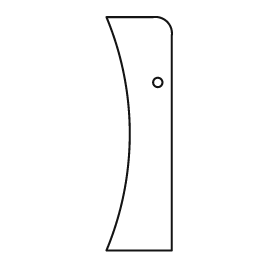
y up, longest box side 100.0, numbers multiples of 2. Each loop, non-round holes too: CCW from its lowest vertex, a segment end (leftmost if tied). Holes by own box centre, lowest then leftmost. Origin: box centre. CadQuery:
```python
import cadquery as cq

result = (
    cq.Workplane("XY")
    .moveTo(-14.0, -50.0)
    .lineTo(14.0, -50.0)
    .lineTo(14.0, 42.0)
    .threePointArc((12.0, 48.0), (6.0, 50.0))
    .lineTo(-14.0, 50.0)
    .threePointArc((-4.0, 0.0), (-14.0, -50.0))
    .close()
    .moveTo(8.0, 22.0)
    .circle(2.0)
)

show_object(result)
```